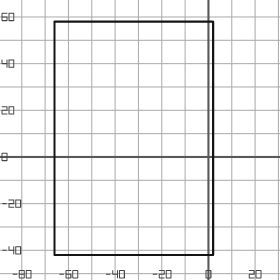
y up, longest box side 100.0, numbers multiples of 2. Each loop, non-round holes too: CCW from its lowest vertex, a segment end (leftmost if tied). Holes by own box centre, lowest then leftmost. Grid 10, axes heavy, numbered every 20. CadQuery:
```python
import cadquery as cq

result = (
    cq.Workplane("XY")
    .moveTo(-66.0, -42.0)
    .lineTo(2.0, -42.0)
    .lineTo(2.0, 58.0)
    .lineTo(-66.0, 58.0)
    .close()
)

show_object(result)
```